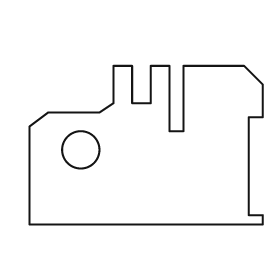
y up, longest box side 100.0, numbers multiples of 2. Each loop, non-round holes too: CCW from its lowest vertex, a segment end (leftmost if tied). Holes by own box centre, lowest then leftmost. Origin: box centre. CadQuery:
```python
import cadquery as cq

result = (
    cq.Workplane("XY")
    .moveTo(-50.0, -34.0)
    .lineTo(50.0, -34.0)
    .lineTo(50.0, -30.0)
    .lineTo(44.0, -30.0)
    .lineTo(44.0, 12.0)
    .lineTo(50.0, 12.0)
    .lineTo(50.0, 26.0)
    .lineTo(42.0, 34.0)
    .lineTo(16.0, 34.0)
    .lineTo(16.0, 6.0)
    .lineTo(10.0, 6.0)
    .lineTo(10.0, 34.0)
    .lineTo(2.0, 34.0)
    .lineTo(2.0, 18.0)
    .lineTo(-6.0, 18.0)
    .lineTo(-6.0, 34.0)
    .lineTo(-14.0, 34.0)
    .lineTo(-14.0, 18.0)
    .lineTo(-20.0, 14.0)
    .lineTo(-42.0, 14.0)
    .lineTo(-50.0, 8.0)
    .close()
    .moveTo(-28.0, -2.0)
    .circle(8.0)
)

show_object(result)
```